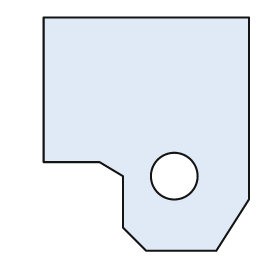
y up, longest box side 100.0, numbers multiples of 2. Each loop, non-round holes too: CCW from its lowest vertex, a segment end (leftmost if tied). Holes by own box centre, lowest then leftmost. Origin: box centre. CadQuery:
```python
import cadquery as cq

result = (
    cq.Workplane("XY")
    .moveTo(0.0, -50.0)
    .lineTo(30.0, -50.0)
    .lineTo(44.0, -28.0)
    .lineTo(44.0, 50.0)
    .lineTo(-44.0, 50.0)
    .lineTo(-44.0, -12.0)
    .lineTo(-20.0, -12.0)
    .lineTo(-10.0, -18.0)
    .lineTo(-10.0, -40.0)
    .close()
    .moveTo(12.0, -18.0)
    .circle(10.0)
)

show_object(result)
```